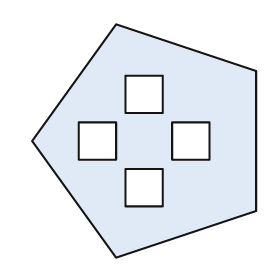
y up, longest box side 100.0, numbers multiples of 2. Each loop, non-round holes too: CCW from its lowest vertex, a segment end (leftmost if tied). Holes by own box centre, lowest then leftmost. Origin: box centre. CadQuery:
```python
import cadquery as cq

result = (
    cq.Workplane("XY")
    .moveTo(-12.0, -50.0)
    .lineTo(48.0, -30.0)
    .lineTo(48.0, 30.0)
    .lineTo(-12.0, 50.0)
    .lineTo(-48.0, 0.0)
    .close()
    .moveTo(-8.0, -28.0)
    .lineTo(8.0, -28.0)
    .lineTo(8.0, -12.0)
    .lineTo(-8.0, -12.0)
    .close()
    .moveTo(-28.0, -8.0)
    .lineTo(-12.0, -8.0)
    .lineTo(-12.0, 8.0)
    .lineTo(-28.0, 8.0)
    .close()
    .moveTo(12.0, -8.0)
    .lineTo(28.0, -8.0)
    .lineTo(28.0, 8.0)
    .lineTo(12.0, 8.0)
    .close()
    .moveTo(-8.0, 12.0)
    .lineTo(8.0, 12.0)
    .lineTo(8.0, 28.0)
    .lineTo(-8.0, 28.0)
    .close()
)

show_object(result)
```